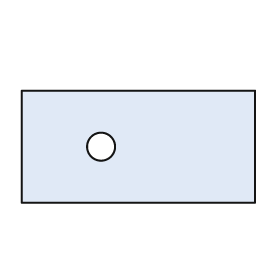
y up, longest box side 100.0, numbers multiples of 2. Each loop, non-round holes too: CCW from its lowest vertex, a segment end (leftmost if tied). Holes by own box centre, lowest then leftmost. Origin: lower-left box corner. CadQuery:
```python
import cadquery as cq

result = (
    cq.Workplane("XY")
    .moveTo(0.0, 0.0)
    .lineTo(100.0, 0.0)
    .lineTo(100.0, 48.0)
    .lineTo(0.0, 48.0)
    .close()
    .moveTo(34.0, 24.0)
    .circle(6.0)
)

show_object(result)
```